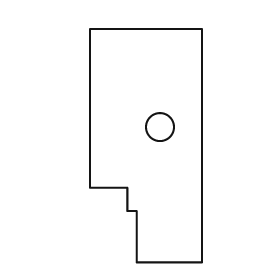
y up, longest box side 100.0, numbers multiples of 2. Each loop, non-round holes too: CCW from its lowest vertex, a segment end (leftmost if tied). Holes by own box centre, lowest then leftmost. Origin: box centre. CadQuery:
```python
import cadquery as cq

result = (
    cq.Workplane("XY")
    .moveTo(-4.0, -50.0)
    .lineTo(24.0, -50.0)
    .lineTo(24.0, 50.0)
    .lineTo(-24.0, 50.0)
    .lineTo(-24.0, -18.0)
    .lineTo(-8.0, -18.0)
    .lineTo(-8.0, -28.0)
    .lineTo(-4.0, -28.0)
    .close()
    .moveTo(6.0, 8.0)
    .circle(6.0)
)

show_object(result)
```